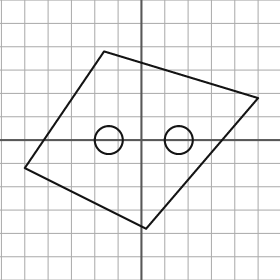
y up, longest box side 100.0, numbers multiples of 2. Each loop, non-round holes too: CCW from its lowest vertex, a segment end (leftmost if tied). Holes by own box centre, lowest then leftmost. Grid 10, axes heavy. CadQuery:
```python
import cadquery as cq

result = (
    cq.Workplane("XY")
    .moveTo(2.0, -38.0)
    .lineTo(50.0, 18.0)
    .lineTo(-16.0, 38.0)
    .lineTo(-50.0, -12.0)
    .close()
    .moveTo(-14.0, 0.0)
    .circle(6.0)
    .moveTo(16.0, 0.0)
    .circle(6.0)
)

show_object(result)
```